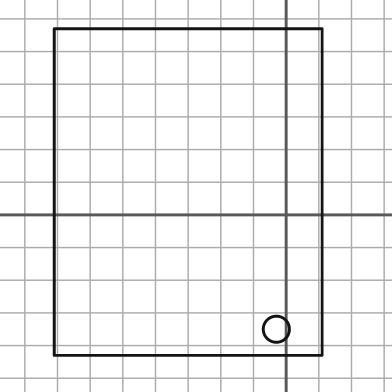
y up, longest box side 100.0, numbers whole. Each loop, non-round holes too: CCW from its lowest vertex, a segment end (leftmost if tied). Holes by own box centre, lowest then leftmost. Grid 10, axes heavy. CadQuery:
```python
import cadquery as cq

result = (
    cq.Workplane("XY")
    .moveTo(-71.0, -43.0)
    .lineTo(11.0, -43.0)
    .lineTo(11.0, 57.0)
    .lineTo(-71.0, 57.0)
    .close()
    .moveTo(-3.0, -35.0)
    .circle(4.0)
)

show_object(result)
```